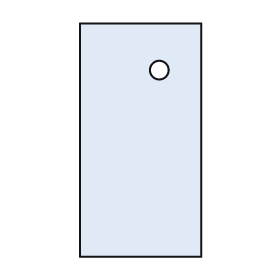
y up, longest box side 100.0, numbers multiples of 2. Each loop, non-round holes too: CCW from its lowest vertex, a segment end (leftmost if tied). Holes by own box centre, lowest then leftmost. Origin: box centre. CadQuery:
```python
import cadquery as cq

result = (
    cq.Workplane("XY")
    .moveTo(-26.0, -50.0)
    .lineTo(26.0, -50.0)
    .lineTo(26.0, 50.0)
    .lineTo(-26.0, 50.0)
    .close()
    .moveTo(8.0, 30.0)
    .circle(4.0)
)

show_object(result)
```